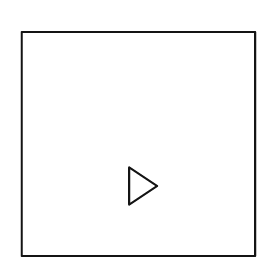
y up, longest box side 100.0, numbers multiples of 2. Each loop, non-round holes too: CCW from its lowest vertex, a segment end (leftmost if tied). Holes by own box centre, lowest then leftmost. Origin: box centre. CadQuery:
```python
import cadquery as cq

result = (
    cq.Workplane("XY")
    .moveTo(-50.0, -48.0)
    .lineTo(50.0, -48.0)
    .lineTo(50.0, 48.0)
    .lineTo(-50.0, 48.0)
    .close()
    .moveTo(-4.0, -26.0)
    .lineTo(8.0, -18.0)
    .lineTo(-4.0, -10.0)
    .close()
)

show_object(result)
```